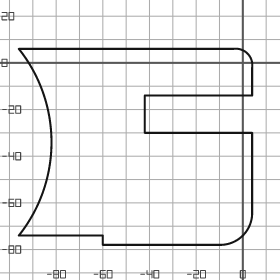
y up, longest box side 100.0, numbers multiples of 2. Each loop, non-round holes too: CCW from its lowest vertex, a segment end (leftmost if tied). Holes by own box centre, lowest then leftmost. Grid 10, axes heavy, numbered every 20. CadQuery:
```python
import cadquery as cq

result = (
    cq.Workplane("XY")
    .moveTo(-60.0, -78.0)
    .lineTo(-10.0, -78.0)
    .threePointArc((0.0, -74.0), (4.0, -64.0))
    .lineTo(4.0, -30.0)
    .lineTo(-42.0, -30.0)
    .lineTo(-42.0, -14.0)
    .lineTo(4.0, -14.0)
    .lineTo(4.0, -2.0)
    .threePointArc((2.0, 4.0), (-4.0, 6.0))
    .lineTo(-96.0, 6.0)
    .threePointArc((-82.0, -34.0), (-96.0, -74.0))
    .lineTo(-60.0, -74.0)
    .close()
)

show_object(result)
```